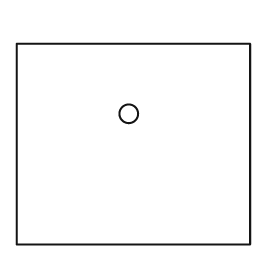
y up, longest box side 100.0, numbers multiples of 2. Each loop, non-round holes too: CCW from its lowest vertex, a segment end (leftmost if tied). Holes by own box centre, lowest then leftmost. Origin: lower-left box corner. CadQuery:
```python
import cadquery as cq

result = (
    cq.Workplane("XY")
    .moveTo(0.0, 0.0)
    .lineTo(100.0, 0.0)
    .lineTo(100.0, 86.0)
    .lineTo(0.0, 86.0)
    .close()
    .moveTo(48.0, 56.0)
    .circle(4.0)
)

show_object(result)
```